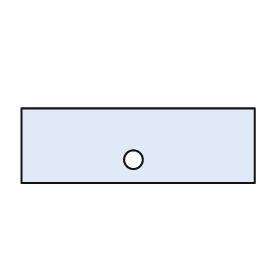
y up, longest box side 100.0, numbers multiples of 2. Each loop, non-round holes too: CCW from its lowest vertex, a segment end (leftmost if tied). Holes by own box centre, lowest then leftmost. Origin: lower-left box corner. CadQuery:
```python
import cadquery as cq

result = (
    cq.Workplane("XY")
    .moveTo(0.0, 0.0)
    .lineTo(100.0, 0.0)
    .lineTo(100.0, 32.0)
    .lineTo(0.0, 32.0)
    .close()
    .moveTo(48.0, 10.0)
    .circle(4.0)
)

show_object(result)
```